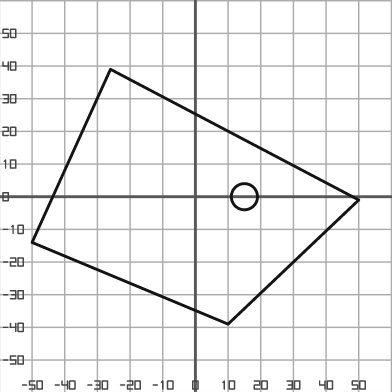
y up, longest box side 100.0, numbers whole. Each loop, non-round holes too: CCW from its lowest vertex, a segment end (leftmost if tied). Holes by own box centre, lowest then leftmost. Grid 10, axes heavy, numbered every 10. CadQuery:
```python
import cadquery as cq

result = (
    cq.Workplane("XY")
    .moveTo(10.0, -39.0)
    .lineTo(50.0, -1.0)
    .lineTo(-26.0, 39.0)
    .lineTo(-50.0, -14.0)
    .close()
    .moveTo(15.0, 0.0)
    .circle(4.0)
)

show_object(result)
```